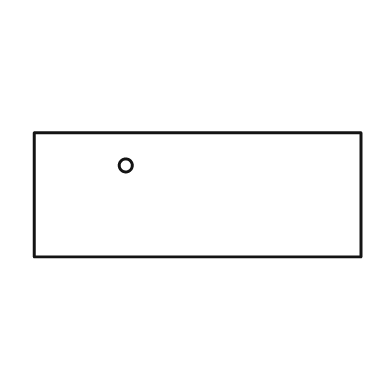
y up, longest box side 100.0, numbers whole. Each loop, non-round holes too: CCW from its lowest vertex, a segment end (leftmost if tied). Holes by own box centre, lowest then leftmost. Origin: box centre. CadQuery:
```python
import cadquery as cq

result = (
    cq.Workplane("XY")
    .moveTo(-50.0, -19.0)
    .lineTo(50.0, -19.0)
    .lineTo(50.0, 19.0)
    .lineTo(-50.0, 19.0)
    .close()
    .moveTo(-22.0, 9.0)
    .circle(2.0)
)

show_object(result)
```